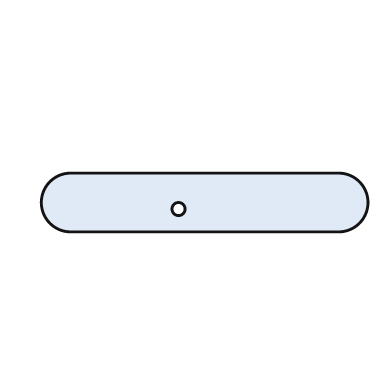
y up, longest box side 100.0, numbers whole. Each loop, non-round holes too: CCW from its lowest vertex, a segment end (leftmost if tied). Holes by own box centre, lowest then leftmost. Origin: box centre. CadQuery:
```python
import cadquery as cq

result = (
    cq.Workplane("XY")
    .moveTo(-41.0, -9.0)
    .lineTo(41.0, -9.0)
    .threePointArc((50.0, 0.0), (41.0, 9.0))
    .lineTo(-41.0, 9.0)
    .threePointArc((-50.0, 0.0), (-41.0, -9.0))
    .close()
    .moveTo(-8.0, -2.0)
    .circle(2.0)
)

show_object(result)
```